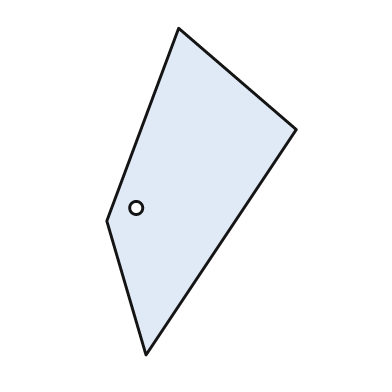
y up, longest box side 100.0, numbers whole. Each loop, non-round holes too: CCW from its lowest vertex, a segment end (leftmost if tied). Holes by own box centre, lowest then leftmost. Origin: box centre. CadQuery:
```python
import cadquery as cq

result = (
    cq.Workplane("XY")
    .moveTo(-17.0, -50.0)
    .lineTo(29.0, 19.0)
    .lineTo(-7.0, 50.0)
    .lineTo(-29.0, -9.0)
    .close()
    .moveTo(-20.0, -5.0)
    .circle(2.0)
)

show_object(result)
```